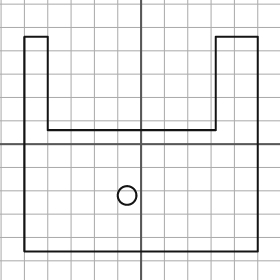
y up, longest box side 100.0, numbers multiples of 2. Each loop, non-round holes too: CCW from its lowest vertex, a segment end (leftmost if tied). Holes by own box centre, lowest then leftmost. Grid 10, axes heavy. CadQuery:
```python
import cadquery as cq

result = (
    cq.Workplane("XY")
    .moveTo(-50.0, -46.0)
    .lineTo(50.0, -46.0)
    .lineTo(50.0, 46.0)
    .lineTo(32.0, 46.0)
    .lineTo(32.0, 6.0)
    .lineTo(-40.0, 6.0)
    .lineTo(-40.0, 46.0)
    .lineTo(-50.0, 46.0)
    .close()
    .moveTo(-6.0, -22.0)
    .circle(4.0)
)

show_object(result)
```